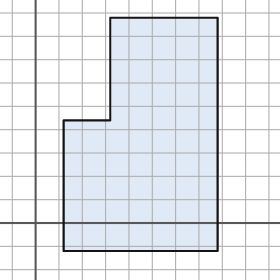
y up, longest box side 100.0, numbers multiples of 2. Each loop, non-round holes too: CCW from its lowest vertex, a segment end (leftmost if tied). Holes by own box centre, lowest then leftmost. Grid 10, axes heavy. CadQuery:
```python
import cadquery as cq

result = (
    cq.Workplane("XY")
    .moveTo(12.0, -12.0)
    .lineTo(78.0, -12.0)
    .lineTo(78.0, 88.0)
    .lineTo(32.0, 88.0)
    .lineTo(32.0, 44.0)
    .lineTo(12.0, 44.0)
    .close()
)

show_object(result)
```